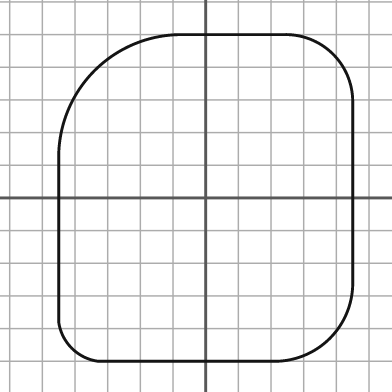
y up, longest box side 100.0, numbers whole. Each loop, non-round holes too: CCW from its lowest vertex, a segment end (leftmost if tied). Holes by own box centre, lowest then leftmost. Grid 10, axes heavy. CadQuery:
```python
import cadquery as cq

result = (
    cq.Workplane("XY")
    .moveTo(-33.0, -50.0)
    .lineTo(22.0, -50.0)
    .threePointArc((38.0, -43.0), (45.0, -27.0))
    .lineTo(45.0, 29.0)
    .threePointArc((39.0, 44.0), (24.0, 50.0))
    .lineTo(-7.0, 50.0)
    .threePointArc((-34.0, 39.0), (-45.0, 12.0))
    .lineTo(-45.0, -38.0)
    .threePointArc((-41.0, -46.0), (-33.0, -50.0))
    .close()
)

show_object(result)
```